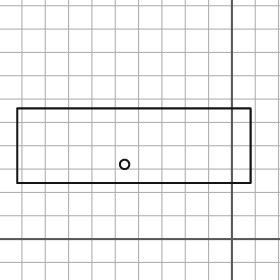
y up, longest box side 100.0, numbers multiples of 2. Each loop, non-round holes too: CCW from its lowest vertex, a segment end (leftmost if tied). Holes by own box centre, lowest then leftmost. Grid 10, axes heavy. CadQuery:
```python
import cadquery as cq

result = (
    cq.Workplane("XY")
    .moveTo(-92.0, 24.0)
    .lineTo(8.0, 24.0)
    .lineTo(8.0, 56.0)
    .lineTo(-92.0, 56.0)
    .close()
    .moveTo(-46.0, 32.0)
    .circle(2.0)
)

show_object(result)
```